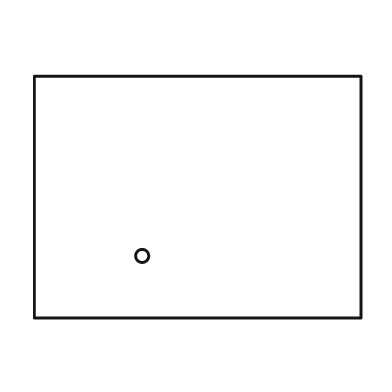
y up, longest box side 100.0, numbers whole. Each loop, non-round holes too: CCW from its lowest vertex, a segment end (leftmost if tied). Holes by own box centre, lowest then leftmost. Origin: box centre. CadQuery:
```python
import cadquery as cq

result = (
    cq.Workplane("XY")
    .moveTo(-50.0, -37.0)
    .lineTo(50.0, -37.0)
    .lineTo(50.0, 37.0)
    .lineTo(-50.0, 37.0)
    .close()
    .moveTo(-17.0, -18.0)
    .circle(2.0)
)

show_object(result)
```